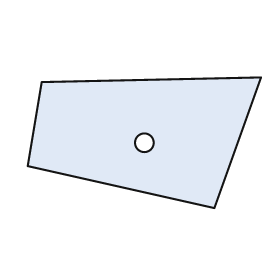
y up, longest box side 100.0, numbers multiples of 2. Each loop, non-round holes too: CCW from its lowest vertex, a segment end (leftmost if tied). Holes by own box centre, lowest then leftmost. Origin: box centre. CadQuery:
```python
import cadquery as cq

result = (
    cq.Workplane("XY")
    .moveTo(30.0, -28.0)
    .lineTo(50.0, 28.0)
    .lineTo(-44.0, 26.0)
    .lineTo(-50.0, -10.0)
    .close()
    .moveTo(0.0, 0.0)
    .circle(4.0)
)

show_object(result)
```